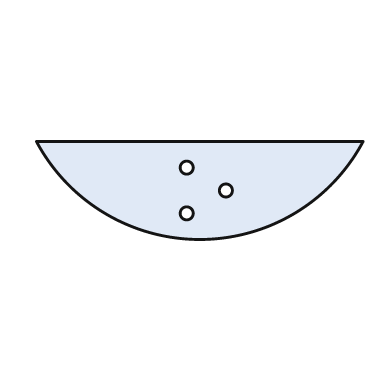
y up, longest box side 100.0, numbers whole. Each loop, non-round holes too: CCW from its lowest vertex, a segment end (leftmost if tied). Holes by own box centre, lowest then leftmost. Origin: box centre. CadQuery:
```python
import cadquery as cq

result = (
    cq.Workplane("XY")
    .moveTo(-50.0, 15.0)
    .threePointArc((0.0, -15.0), (50.0, 15.0))
    .close()
    .moveTo(-4.0, -7.0)
    .circle(2.0)
    .moveTo(8.0, 0.0)
    .circle(2.0)
    .moveTo(-4.0, 7.0)
    .circle(2.0)
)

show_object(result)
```